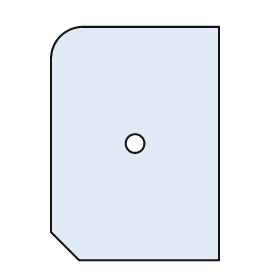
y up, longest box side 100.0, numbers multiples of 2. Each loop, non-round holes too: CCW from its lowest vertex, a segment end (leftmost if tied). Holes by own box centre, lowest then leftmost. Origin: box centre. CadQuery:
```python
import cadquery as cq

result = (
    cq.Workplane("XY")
    .moveTo(-24.0, -50.0)
    .lineTo(36.0, -50.0)
    .lineTo(36.0, 50.0)
    .lineTo(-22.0, 50.0)
    .threePointArc((-32.0, 46.0), (-36.0, 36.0))
    .lineTo(-36.0, -38.0)
    .close()
    .moveTo(0.0, 0.0)
    .circle(4.0)
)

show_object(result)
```